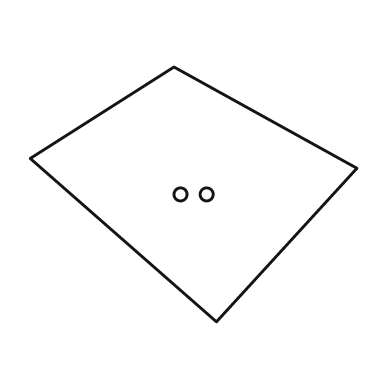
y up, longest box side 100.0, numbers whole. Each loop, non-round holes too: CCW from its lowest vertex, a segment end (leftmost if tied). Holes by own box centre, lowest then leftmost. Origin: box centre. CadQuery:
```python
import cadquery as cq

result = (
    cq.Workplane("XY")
    .moveTo(7.0, -39.0)
    .lineTo(50.0, 8.0)
    .lineTo(-6.0, 39.0)
    .lineTo(-50.0, 11.0)
    .close()
    .moveTo(-4.0, 0.0)
    .circle(2.0)
    .moveTo(4.0, 0.0)
    .circle(2.0)
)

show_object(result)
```